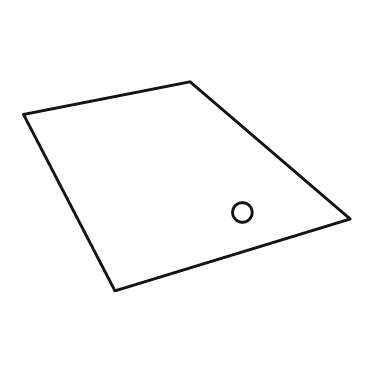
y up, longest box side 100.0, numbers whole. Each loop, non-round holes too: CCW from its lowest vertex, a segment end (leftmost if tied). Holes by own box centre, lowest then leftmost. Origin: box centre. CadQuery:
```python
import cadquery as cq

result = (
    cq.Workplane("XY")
    .moveTo(-22.0, -32.0)
    .lineTo(50.0, -10.0)
    .lineTo(1.0, 32.0)
    .lineTo(-50.0, 22.0)
    .close()
    .moveTo(17.0, -8.0)
    .circle(3.0)
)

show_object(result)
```